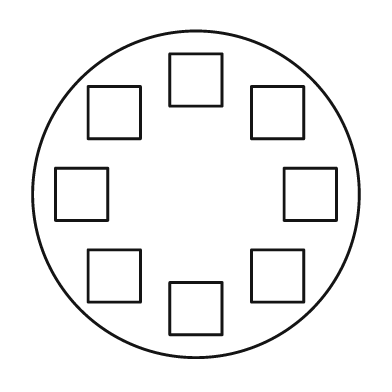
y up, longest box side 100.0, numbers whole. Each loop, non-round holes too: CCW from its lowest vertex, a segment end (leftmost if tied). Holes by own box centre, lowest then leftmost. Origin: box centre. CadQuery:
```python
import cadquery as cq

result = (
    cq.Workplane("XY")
    .moveTo(0.0, 0.0)
    .circle(50.0)
    .moveTo(-8.0, -43.0)
    .lineTo(8.0, -43.0)
    .lineTo(8.0, -27.0)
    .lineTo(-8.0, -27.0)
    .close()
    .moveTo(-33.0, -33.0)
    .lineTo(-17.0, -33.0)
    .lineTo(-17.0, -17.0)
    .lineTo(-33.0, -17.0)
    .close()
    .moveTo(17.0, -33.0)
    .lineTo(33.0, -33.0)
    .lineTo(33.0, -17.0)
    .lineTo(17.0, -17.0)
    .close()
    .moveTo(-43.0, -8.0)
    .lineTo(-27.0, -8.0)
    .lineTo(-27.0, 8.0)
    .lineTo(-43.0, 8.0)
    .close()
    .moveTo(27.0, -8.0)
    .lineTo(43.0, -8.0)
    .lineTo(43.0, 8.0)
    .lineTo(27.0, 8.0)
    .close()
    .moveTo(-33.0, 17.0)
    .lineTo(-17.0, 17.0)
    .lineTo(-17.0, 33.0)
    .lineTo(-33.0, 33.0)
    .close()
    .moveTo(17.0, 17.0)
    .lineTo(33.0, 17.0)
    .lineTo(33.0, 33.0)
    .lineTo(17.0, 33.0)
    .close()
    .moveTo(-8.0, 27.0)
    .lineTo(8.0, 27.0)
    .lineTo(8.0, 43.0)
    .lineTo(-8.0, 43.0)
    .close()
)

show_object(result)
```